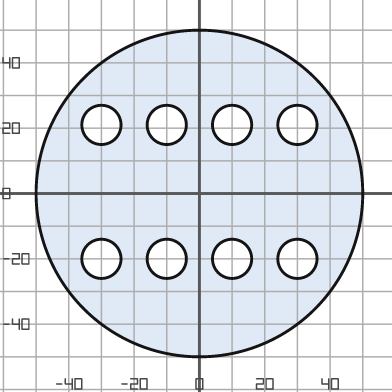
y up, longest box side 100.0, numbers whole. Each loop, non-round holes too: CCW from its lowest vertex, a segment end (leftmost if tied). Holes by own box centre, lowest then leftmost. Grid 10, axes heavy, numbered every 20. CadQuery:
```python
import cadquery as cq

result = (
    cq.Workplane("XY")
    .moveTo(0.0, 0.0)
    .circle(50.0)
    .moveTo(-30.0, -20.0)
    .circle(6.0)
    .moveTo(-10.0, -20.0)
    .circle(6.0)
    .moveTo(10.0, -20.0)
    .circle(6.0)
    .moveTo(30.0, -20.0)
    .circle(6.0)
    .moveTo(-30.0, 21.0)
    .circle(6.0)
    .moveTo(-10.0, 21.0)
    .circle(6.0)
    .moveTo(10.0, 21.0)
    .circle(6.0)
    .moveTo(30.0, 21.0)
    .circle(6.0)
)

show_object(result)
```